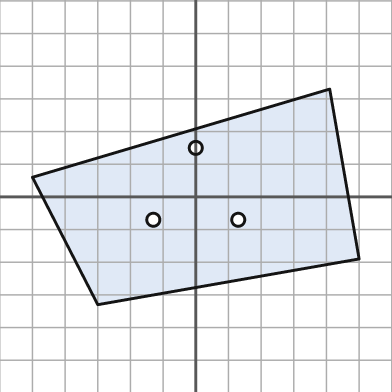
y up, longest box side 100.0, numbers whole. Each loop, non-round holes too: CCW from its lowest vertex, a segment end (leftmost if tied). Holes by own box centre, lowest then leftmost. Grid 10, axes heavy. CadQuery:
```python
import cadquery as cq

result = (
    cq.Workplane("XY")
    .moveTo(-30.0, -33.0)
    .lineTo(50.0, -19.0)
    .lineTo(41.0, 33.0)
    .lineTo(-50.0, 6.0)
    .close()
    .moveTo(-13.0, -7.0)
    .circle(2.0)
    .moveTo(13.0, -7.0)
    .circle(2.0)
    .moveTo(0.0, 15.0)
    .circle(2.0)
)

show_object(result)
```